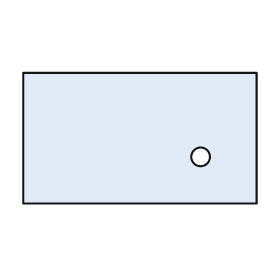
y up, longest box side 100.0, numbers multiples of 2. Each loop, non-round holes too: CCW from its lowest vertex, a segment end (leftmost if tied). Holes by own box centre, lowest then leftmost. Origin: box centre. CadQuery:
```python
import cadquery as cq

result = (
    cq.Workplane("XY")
    .moveTo(-50.0, -28.0)
    .lineTo(50.0, -28.0)
    .lineTo(50.0, 28.0)
    .lineTo(-50.0, 28.0)
    .close()
    .moveTo(26.0, -8.0)
    .circle(4.0)
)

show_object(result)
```